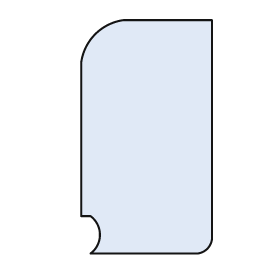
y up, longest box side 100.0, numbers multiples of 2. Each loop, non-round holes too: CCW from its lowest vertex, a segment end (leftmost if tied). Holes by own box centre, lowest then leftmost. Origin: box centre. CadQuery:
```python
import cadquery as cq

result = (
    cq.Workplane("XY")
    .moveTo(-24.0, -50.0)
    .lineTo(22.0, -50.0)
    .threePointArc((26.0, -48.0), (28.0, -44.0))
    .lineTo(28.0, 50.0)
    .lineTo(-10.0, 50.0)
    .threePointArc((-22.0, 44.0), (-28.0, 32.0))
    .lineTo(-28.0, -34.0)
    .lineTo(-24.0, -34.0)
    .threePointArc((-20.0, -42.0), (-24.0, -50.0))
    .close()
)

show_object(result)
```